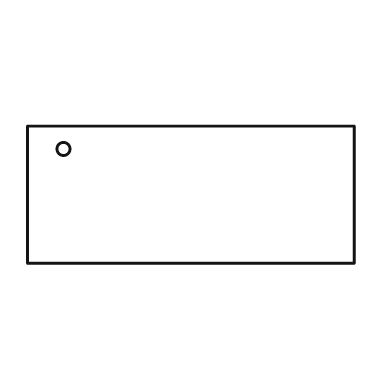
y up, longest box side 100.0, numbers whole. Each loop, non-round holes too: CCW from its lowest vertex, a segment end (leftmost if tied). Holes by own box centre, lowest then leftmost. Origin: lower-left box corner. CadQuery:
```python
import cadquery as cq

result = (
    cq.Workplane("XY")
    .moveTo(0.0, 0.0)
    .lineTo(100.0, 0.0)
    .lineTo(100.0, 42.0)
    .lineTo(0.0, 42.0)
    .close()
    .moveTo(11.0, 35.0)
    .circle(2.0)
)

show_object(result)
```